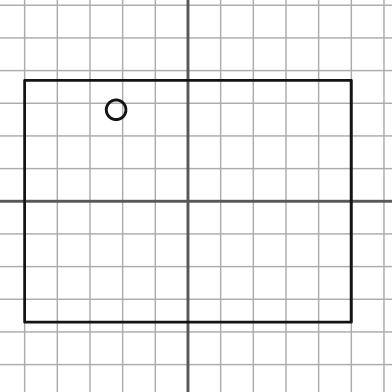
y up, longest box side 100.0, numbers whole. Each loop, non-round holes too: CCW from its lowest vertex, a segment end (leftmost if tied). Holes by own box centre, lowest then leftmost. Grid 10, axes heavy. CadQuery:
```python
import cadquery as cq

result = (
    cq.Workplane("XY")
    .moveTo(-50.0, -37.0)
    .lineTo(50.0, -37.0)
    .lineTo(50.0, 37.0)
    .lineTo(-50.0, 37.0)
    .close()
    .moveTo(-22.0, 28.0)
    .circle(3.0)
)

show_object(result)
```